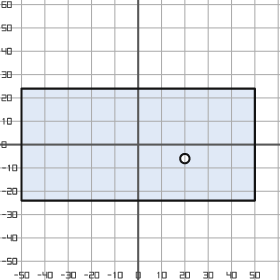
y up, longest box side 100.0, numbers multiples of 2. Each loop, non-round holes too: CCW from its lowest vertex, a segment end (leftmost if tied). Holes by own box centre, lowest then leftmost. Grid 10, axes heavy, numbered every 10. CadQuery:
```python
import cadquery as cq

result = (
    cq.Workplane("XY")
    .moveTo(-50.0, -24.0)
    .lineTo(50.0, -24.0)
    .lineTo(50.0, 24.0)
    .lineTo(-50.0, 24.0)
    .close()
    .moveTo(20.0, -6.0)
    .circle(2.0)
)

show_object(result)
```